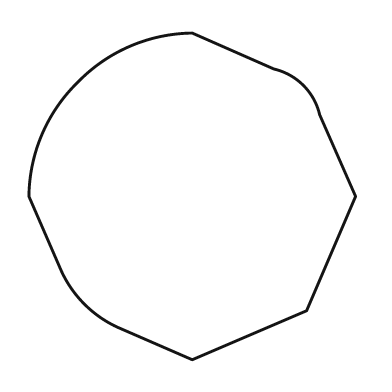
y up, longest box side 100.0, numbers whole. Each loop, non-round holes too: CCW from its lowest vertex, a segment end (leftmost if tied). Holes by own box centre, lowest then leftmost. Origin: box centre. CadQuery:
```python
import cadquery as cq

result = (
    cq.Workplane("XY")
    .moveTo(0.0, -50.0)
    .lineTo(35.0, -35.0)
    .lineTo(50.0, 0.0)
    .lineTo(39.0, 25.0)
    .threePointArc((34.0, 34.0), (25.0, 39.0))
    .lineTo(0.0, 50.0)
    .threePointArc((-19.0, 46.0), (-35.0, 35.0))
    .threePointArc((-46.0, 19.0), (-50.0, 0.0))
    .lineTo(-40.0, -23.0)
    .threePointArc((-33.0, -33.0), (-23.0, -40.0))
    .close()
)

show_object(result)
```